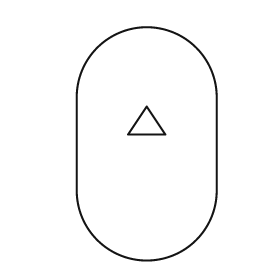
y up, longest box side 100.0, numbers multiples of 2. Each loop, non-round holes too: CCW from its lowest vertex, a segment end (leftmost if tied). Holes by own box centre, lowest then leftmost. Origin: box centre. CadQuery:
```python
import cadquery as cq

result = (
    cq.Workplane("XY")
    .moveTo(-30.0, -20.0)
    .threePointArc((0.0, -50.0), (30.0, -20.0))
    .lineTo(30.0, 20.0)
    .threePointArc((0.0, 50.0), (-30.0, 20.0))
    .close()
    .moveTo(-8.0, 4.0)
    .lineTo(8.0, 4.0)
    .lineTo(0.0, 16.0)
    .close()
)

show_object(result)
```